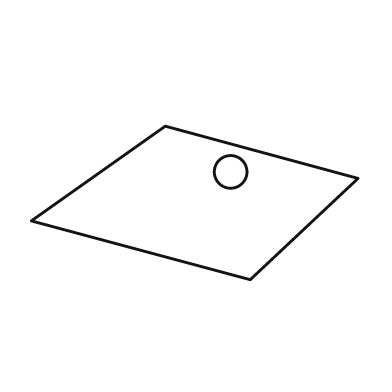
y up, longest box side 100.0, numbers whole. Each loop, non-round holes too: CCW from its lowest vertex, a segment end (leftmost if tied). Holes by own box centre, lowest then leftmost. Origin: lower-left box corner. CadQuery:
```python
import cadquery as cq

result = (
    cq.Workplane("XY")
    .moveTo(67.0, 0.0)
    .lineTo(100.0, 31.0)
    .lineTo(41.0, 47.0)
    .lineTo(0.0, 18.0)
    .close()
    .moveTo(61.0, 33.0)
    .circle(5.0)
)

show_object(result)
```